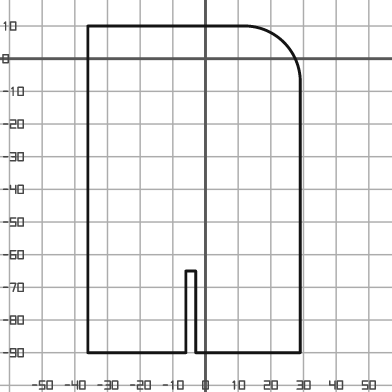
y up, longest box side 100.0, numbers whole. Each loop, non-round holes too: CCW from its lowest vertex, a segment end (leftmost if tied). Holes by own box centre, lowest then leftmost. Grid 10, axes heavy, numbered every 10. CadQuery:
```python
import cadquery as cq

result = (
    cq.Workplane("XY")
    .moveTo(-36.0, -90.0)
    .lineTo(-6.0, -90.0)
    .lineTo(-6.0, -65.0)
    .lineTo(-3.0, -65.0)
    .lineTo(-3.0, -90.0)
    .lineTo(29.0, -90.0)
    .lineTo(29.0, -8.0)
    .threePointArc((24.0, 5.0), (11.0, 10.0))
    .lineTo(-36.0, 10.0)
    .close()
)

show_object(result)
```